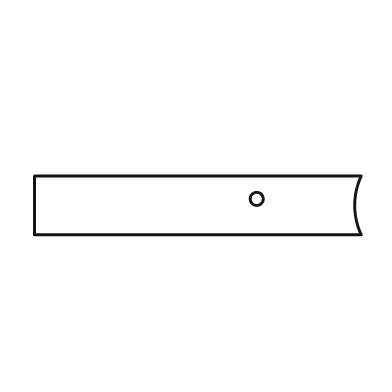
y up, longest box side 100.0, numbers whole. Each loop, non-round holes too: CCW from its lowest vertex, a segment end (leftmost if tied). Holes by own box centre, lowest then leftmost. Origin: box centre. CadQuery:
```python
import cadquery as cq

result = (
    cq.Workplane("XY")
    .moveTo(-50.0, -9.0)
    .lineTo(50.0, -9.0)
    .threePointArc((48.0, 0.0), (50.0, 9.0))
    .lineTo(-50.0, 9.0)
    .close()
    .moveTo(18.0, 2.0)
    .circle(2.0)
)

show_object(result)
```